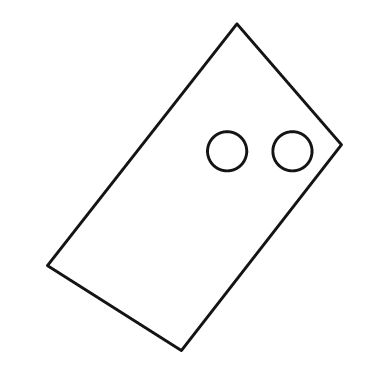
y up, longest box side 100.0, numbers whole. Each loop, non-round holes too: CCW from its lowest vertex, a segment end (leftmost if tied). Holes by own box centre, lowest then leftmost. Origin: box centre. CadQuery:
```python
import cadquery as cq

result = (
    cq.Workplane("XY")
    .moveTo(-4.0, -50.0)
    .lineTo(45.0, 13.0)
    .lineTo(13.0, 50.0)
    .lineTo(-45.0, -24.0)
    .close()
    .moveTo(10.0, 11.0)
    .circle(6.0)
    .moveTo(30.0, 11.0)
    .circle(6.0)
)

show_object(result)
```